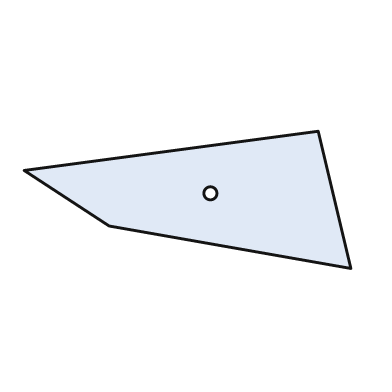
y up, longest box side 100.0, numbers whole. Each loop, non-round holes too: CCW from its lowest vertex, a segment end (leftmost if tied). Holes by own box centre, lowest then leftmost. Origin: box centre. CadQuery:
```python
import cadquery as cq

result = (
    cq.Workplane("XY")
    .moveTo(50.0, -21.0)
    .lineTo(40.0, 21.0)
    .lineTo(-50.0, 9.0)
    .lineTo(-24.0, -8.0)
    .close()
    .moveTo(7.0, 2.0)
    .circle(2.0)
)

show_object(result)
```